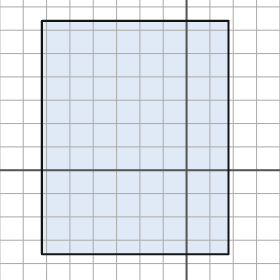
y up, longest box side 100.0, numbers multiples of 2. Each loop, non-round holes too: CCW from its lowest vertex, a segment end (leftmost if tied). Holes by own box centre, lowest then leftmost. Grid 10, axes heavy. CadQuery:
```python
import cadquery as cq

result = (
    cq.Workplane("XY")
    .moveTo(-62.0, -36.0)
    .lineTo(18.0, -36.0)
    .lineTo(18.0, 64.0)
    .lineTo(-62.0, 64.0)
    .close()
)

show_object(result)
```